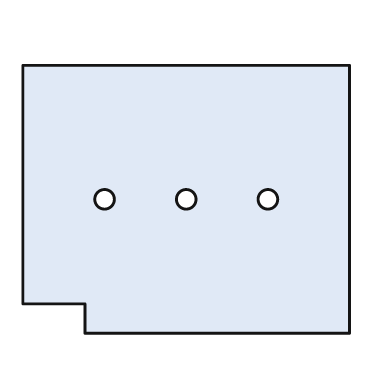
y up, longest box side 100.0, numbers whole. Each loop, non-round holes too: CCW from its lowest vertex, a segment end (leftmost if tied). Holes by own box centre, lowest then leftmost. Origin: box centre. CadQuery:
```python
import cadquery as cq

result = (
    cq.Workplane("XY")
    .moveTo(-31.0, -41.0)
    .lineTo(50.0, -41.0)
    .lineTo(50.0, 41.0)
    .lineTo(-50.0, 41.0)
    .lineTo(-50.0, -32.0)
    .lineTo(-31.0, -32.0)
    .close()
    .moveTo(-25.0, 0.0)
    .circle(3.0)
    .moveTo(0.0, 0.0)
    .circle(3.0)
    .moveTo(25.0, 0.0)
    .circle(3.0)
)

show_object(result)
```